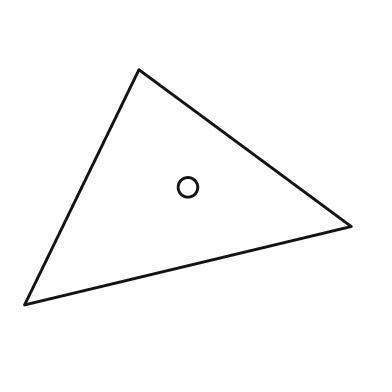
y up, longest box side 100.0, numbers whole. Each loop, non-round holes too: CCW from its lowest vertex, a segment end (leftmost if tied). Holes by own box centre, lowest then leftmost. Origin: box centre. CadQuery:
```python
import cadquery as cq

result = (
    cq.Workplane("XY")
    .moveTo(-50.0, -36.0)
    .lineTo(50.0, -12.0)
    .lineTo(-15.0, 36.0)
    .close()
    .moveTo(0.0, 0.0)
    .circle(3.0)
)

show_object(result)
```